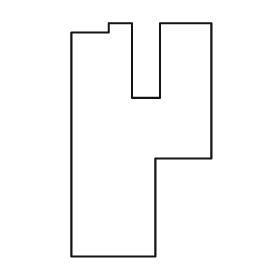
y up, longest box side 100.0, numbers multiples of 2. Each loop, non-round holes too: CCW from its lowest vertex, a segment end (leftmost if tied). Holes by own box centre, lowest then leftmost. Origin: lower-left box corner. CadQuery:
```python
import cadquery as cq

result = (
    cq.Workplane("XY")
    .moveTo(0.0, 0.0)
    .lineTo(36.0, 0.0)
    .lineTo(36.0, 42.0)
    .lineTo(60.0, 42.0)
    .lineTo(60.0, 100.0)
    .lineTo(38.0, 100.0)
    .lineTo(38.0, 68.0)
    .lineTo(26.0, 68.0)
    .lineTo(26.0, 100.0)
    .lineTo(16.0, 100.0)
    .lineTo(16.0, 96.0)
    .lineTo(0.0, 96.0)
    .close()
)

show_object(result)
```